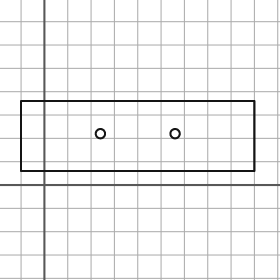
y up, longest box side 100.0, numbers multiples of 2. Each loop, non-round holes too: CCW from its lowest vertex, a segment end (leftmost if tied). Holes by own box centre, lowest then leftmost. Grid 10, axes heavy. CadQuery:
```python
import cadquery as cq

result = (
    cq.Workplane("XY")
    .moveTo(-10.0, 6.0)
    .lineTo(90.0, 6.0)
    .lineTo(90.0, 36.0)
    .lineTo(-10.0, 36.0)
    .close()
    .moveTo(24.0, 22.0)
    .circle(2.0)
    .moveTo(56.0, 22.0)
    .circle(2.0)
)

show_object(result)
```